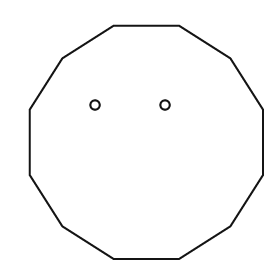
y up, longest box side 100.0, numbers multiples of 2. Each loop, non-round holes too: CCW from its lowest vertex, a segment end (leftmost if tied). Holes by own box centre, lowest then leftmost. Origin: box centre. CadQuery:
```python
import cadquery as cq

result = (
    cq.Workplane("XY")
    .moveTo(-14.0, -50.0)
    .lineTo(14.0, -50.0)
    .lineTo(36.0, -36.0)
    .lineTo(50.0, -14.0)
    .lineTo(50.0, 14.0)
    .lineTo(36.0, 36.0)
    .lineTo(14.0, 50.0)
    .lineTo(-14.0, 50.0)
    .lineTo(-36.0, 36.0)
    .lineTo(-50.0, 14.0)
    .lineTo(-50.0, -14.0)
    .lineTo(-36.0, -36.0)
    .close()
    .moveTo(-22.0, 16.0)
    .circle(2.0)
    .moveTo(8.0, 16.0)
    .circle(2.0)
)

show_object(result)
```